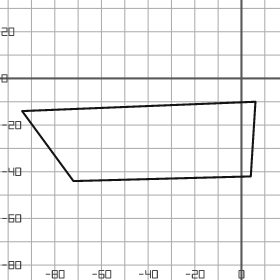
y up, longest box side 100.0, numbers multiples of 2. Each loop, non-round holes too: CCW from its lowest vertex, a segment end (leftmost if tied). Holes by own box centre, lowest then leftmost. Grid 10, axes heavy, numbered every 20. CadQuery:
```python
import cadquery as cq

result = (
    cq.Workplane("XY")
    .moveTo(-72.0, -44.0)
    .lineTo(4.0, -42.0)
    .lineTo(6.0, -10.0)
    .lineTo(-94.0, -14.0)
    .close()
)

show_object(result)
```